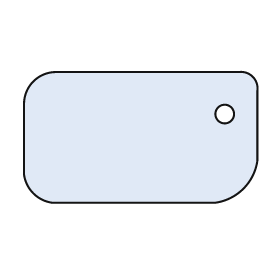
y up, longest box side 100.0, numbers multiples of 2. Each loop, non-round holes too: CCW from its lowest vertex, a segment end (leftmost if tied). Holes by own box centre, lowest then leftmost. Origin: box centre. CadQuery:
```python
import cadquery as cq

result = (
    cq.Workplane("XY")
    .moveTo(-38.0, -28.0)
    .lineTo(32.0, -28.0)
    .threePointArc((44.0, -22.0), (50.0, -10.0))
    .lineTo(50.0, 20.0)
    .threePointArc((48.0, 26.0), (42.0, 28.0))
    .lineTo(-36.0, 28.0)
    .threePointArc((-46.0, 24.0), (-50.0, 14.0))
    .lineTo(-50.0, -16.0)
    .threePointArc((-46.0, -24.0), (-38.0, -28.0))
    .close()
    .moveTo(36.0, 10.0)
    .circle(4.0)
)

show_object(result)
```